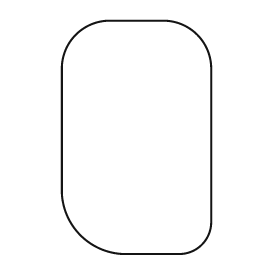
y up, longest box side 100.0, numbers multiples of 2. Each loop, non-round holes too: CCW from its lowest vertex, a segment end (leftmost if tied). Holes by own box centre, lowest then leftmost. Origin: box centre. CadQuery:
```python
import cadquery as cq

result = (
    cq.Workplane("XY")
    .moveTo(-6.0, -50.0)
    .lineTo(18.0, -50.0)
    .threePointArc((28.0, -46.0), (32.0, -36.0))
    .lineTo(32.0, 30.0)
    .threePointArc((26.0, 44.0), (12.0, 50.0))
    .lineTo(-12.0, 50.0)
    .threePointArc((-26.0, 44.0), (-32.0, 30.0))
    .lineTo(-32.0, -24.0)
    .threePointArc((-24.0, -42.0), (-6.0, -50.0))
    .close()
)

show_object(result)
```